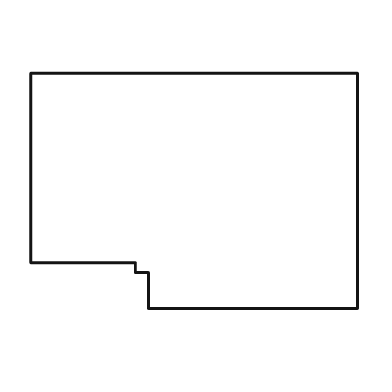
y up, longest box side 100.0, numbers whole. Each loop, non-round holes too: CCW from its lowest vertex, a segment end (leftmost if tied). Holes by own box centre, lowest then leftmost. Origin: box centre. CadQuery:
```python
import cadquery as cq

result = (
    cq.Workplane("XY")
    .moveTo(-14.0, -36.0)
    .lineTo(50.0, -36.0)
    .lineTo(50.0, 36.0)
    .lineTo(-50.0, 36.0)
    .lineTo(-50.0, -22.0)
    .lineTo(-18.0, -22.0)
    .lineTo(-18.0, -25.0)
    .lineTo(-14.0, -25.0)
    .close()
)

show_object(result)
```